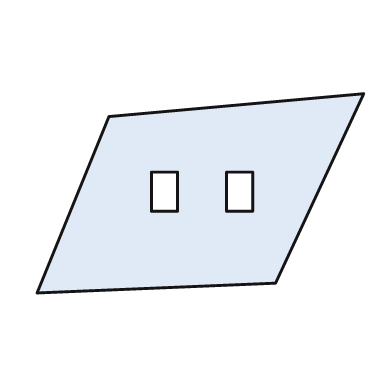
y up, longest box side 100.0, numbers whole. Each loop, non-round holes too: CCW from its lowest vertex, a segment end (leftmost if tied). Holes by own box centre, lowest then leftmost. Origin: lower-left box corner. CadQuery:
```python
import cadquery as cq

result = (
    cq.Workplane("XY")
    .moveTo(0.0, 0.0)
    .lineTo(73.0, 3.0)
    .lineTo(100.0, 61.0)
    .lineTo(22.0, 54.0)
    .close()
    .moveTo(35.0, 25.0)
    .lineTo(43.0, 25.0)
    .lineTo(43.0, 37.0)
    .lineTo(35.0, 37.0)
    .close()
    .moveTo(58.0, 25.0)
    .lineTo(66.0, 25.0)
    .lineTo(66.0, 37.0)
    .lineTo(58.0, 37.0)
    .close()
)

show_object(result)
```